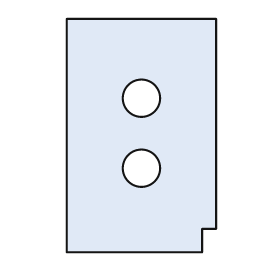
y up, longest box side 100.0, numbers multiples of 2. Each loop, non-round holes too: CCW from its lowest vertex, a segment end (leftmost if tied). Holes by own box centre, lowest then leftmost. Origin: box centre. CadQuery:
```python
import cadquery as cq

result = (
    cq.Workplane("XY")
    .moveTo(-32.0, -50.0)
    .lineTo(26.0, -50.0)
    .lineTo(26.0, -40.0)
    .lineTo(32.0, -40.0)
    .lineTo(32.0, 50.0)
    .lineTo(-32.0, 50.0)
    .close()
    .moveTo(0.0, -14.0)
    .circle(8.0)
    .moveTo(0.0, 16.0)
    .circle(8.0)
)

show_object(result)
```